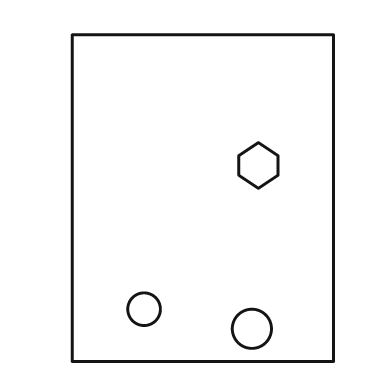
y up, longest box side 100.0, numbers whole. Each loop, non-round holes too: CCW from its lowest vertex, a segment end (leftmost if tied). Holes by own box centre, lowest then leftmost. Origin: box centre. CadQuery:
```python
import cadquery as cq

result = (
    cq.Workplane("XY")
    .moveTo(-40.0, -50.0)
    .lineTo(40.0, -50.0)
    .lineTo(40.0, 50.0)
    .lineTo(-40.0, 50.0)
    .close()
    .moveTo(15.0, -40.0)
    .circle(6.0)
    .moveTo(-18.0, -34.0)
    .circle(5.0)
    .moveTo(17.0, 3.0)
    .lineTo(23.0, 7.0)
    .lineTo(23.0, 13.0)
    .lineTo(17.0, 17.0)
    .lineTo(11.0, 13.0)
    .lineTo(11.0, 7.0)
    .close()
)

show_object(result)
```